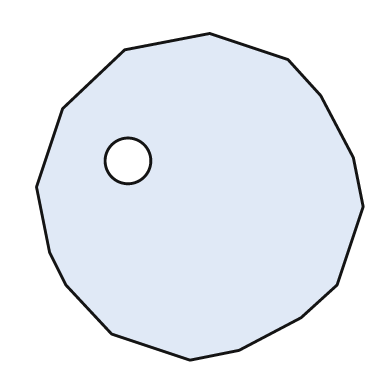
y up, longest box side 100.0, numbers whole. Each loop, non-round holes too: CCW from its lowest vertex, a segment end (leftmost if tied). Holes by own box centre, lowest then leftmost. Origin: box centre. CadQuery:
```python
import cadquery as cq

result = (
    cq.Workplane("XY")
    .moveTo(-3.0, -50.0)
    .lineTo(12.0, -47.0)
    .lineTo(31.0, -37.0)
    .lineTo(42.0, -27.0)
    .lineTo(50.0, -3.0)
    .lineTo(47.0, 12.0)
    .lineTo(37.0, 31.0)
    .lineTo(27.0, 42.0)
    .lineTo(3.0, 50.0)
    .lineTo(-23.0, 45.0)
    .lineTo(-42.0, 27.0)
    .lineTo(-50.0, 3.0)
    .lineTo(-46.0, -17.0)
    .lineTo(-41.0, -27.0)
    .lineTo(-27.0, -42.0)
    .close()
    .moveTo(-22.0, 11.0)
    .circle(7.0)
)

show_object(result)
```